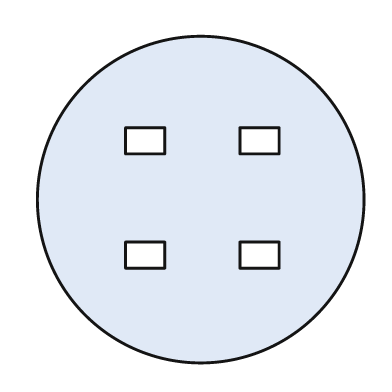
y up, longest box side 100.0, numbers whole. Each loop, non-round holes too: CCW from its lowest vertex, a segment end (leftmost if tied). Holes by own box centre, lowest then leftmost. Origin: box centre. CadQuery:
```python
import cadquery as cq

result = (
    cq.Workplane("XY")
    .moveTo(0.0, 0.0)
    .circle(50.0)
    .moveTo(-23.0, -21.0)
    .lineTo(-11.0, -21.0)
    .lineTo(-11.0, -13.0)
    .lineTo(-23.0, -13.0)
    .close()
    .moveTo(12.0, -21.0)
    .lineTo(24.0, -21.0)
    .lineTo(24.0, -13.0)
    .lineTo(12.0, -13.0)
    .close()
    .moveTo(-23.0, 14.0)
    .lineTo(-11.0, 14.0)
    .lineTo(-11.0, 22.0)
    .lineTo(-23.0, 22.0)
    .close()
    .moveTo(12.0, 14.0)
    .lineTo(24.0, 14.0)
    .lineTo(24.0, 22.0)
    .lineTo(12.0, 22.0)
    .close()
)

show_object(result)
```